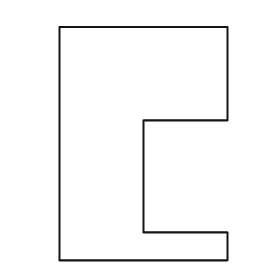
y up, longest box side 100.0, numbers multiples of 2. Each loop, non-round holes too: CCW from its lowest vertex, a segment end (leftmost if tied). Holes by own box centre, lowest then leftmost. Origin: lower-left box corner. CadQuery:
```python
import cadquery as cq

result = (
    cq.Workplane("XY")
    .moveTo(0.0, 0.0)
    .lineTo(72.0, 0.0)
    .lineTo(72.0, 12.0)
    .lineTo(36.0, 12.0)
    .lineTo(36.0, 60.0)
    .lineTo(72.0, 60.0)
    .lineTo(72.0, 100.0)
    .lineTo(0.0, 100.0)
    .close()
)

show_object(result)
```